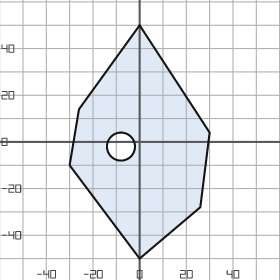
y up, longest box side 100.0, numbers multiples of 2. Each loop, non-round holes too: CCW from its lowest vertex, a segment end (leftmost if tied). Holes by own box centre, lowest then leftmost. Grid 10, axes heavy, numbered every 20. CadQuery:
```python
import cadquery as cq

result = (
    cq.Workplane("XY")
    .moveTo(0.0, -50.0)
    .lineTo(26.0, -28.0)
    .lineTo(30.0, 4.0)
    .lineTo(0.0, 50.0)
    .lineTo(-26.0, 14.0)
    .lineTo(-30.0, -10.0)
    .close()
    .moveTo(-8.0, -2.0)
    .circle(6.0)
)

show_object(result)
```